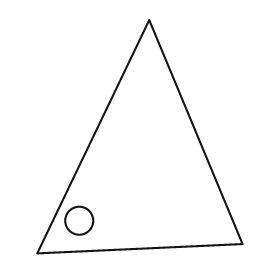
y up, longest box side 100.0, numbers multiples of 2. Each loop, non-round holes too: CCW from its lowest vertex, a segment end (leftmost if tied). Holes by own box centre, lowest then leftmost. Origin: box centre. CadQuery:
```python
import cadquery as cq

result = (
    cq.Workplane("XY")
    .moveTo(-44.0, -50.0)
    .lineTo(44.0, -46.0)
    .lineTo(4.0, 50.0)
    .close()
    .moveTo(-26.0, -36.0)
    .circle(6.0)
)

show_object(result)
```